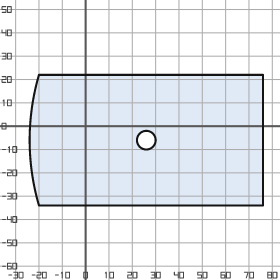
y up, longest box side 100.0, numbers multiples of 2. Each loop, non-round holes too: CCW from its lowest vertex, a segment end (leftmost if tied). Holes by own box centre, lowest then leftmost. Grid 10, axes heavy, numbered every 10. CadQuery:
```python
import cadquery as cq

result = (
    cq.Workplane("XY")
    .moveTo(-20.0, -34.0)
    .lineTo(76.0, -34.0)
    .lineTo(76.0, 22.0)
    .lineTo(-20.0, 22.0)
    .threePointArc((-24.0, -6.0), (-20.0, -34.0))
    .close()
    .moveTo(26.0, -6.0)
    .circle(4.0)
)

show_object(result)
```